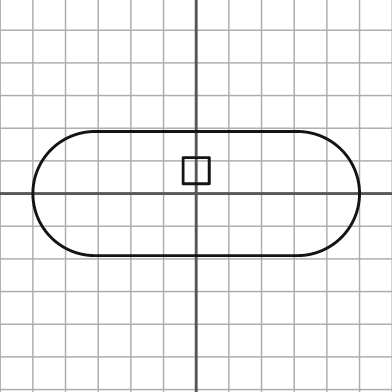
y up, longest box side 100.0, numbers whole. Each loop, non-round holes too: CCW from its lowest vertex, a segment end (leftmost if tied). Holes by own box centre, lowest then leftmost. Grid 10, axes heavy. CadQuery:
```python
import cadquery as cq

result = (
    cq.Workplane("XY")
    .moveTo(-31.0, -19.0)
    .lineTo(31.0, -19.0)
    .threePointArc((50.0, 0.0), (31.0, 19.0))
    .lineTo(-31.0, 19.0)
    .threePointArc((-50.0, 0.0), (-31.0, -19.0))
    .close()
    .moveTo(-4.0, 3.0)
    .lineTo(4.0, 3.0)
    .lineTo(4.0, 11.0)
    .lineTo(-4.0, 11.0)
    .close()
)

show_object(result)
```